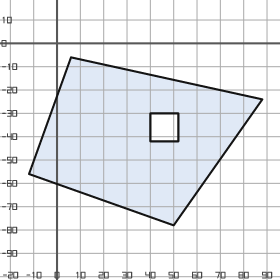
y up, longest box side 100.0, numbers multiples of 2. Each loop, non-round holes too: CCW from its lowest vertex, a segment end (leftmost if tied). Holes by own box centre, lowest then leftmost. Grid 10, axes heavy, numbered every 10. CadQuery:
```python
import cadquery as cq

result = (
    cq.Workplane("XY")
    .moveTo(50.0, -78.0)
    .lineTo(88.0, -24.0)
    .lineTo(6.0, -6.0)
    .lineTo(-12.0, -56.0)
    .close()
    .moveTo(40.0, -42.0)
    .lineTo(52.0, -42.0)
    .lineTo(52.0, -30.0)
    .lineTo(40.0, -30.0)
    .close()
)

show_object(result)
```